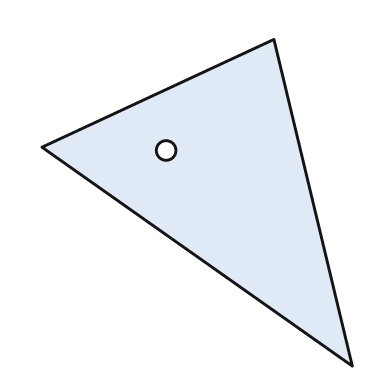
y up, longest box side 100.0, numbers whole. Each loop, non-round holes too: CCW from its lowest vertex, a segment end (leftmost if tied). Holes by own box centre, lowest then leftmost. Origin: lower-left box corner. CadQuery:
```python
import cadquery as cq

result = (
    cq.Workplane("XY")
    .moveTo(95.0, 0.0)
    .lineTo(71.0, 100.0)
    .lineTo(0.0, 67.0)
    .close()
    .moveTo(38.0, 66.0)
    .circle(3.0)
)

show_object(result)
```